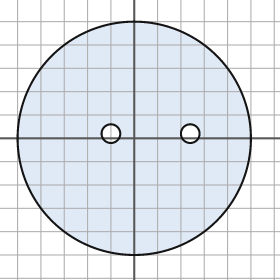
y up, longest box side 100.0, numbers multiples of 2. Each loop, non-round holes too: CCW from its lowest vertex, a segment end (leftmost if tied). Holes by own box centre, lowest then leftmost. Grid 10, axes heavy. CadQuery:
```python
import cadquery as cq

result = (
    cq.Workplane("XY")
    .moveTo(0.0, 0.0)
    .circle(50.0)
    .moveTo(-10.0, 2.0)
    .circle(4.0)
    .moveTo(24.0, 2.0)
    .circle(4.0)
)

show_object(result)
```